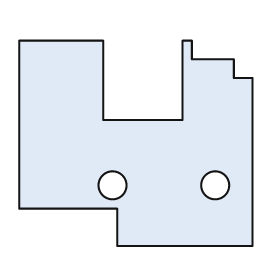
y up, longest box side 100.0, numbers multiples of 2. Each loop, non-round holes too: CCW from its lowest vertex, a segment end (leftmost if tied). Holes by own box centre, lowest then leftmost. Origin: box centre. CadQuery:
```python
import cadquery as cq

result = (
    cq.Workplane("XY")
    .moveTo(-8.0, -44.0)
    .lineTo(50.0, -44.0)
    .lineTo(50.0, 28.0)
    .lineTo(42.0, 28.0)
    .lineTo(42.0, 36.0)
    .lineTo(24.0, 36.0)
    .lineTo(24.0, 44.0)
    .lineTo(20.0, 44.0)
    .lineTo(20.0, 10.0)
    .lineTo(-14.0, 10.0)
    .lineTo(-14.0, 44.0)
    .lineTo(-50.0, 44.0)
    .lineTo(-50.0, -28.0)
    .lineTo(-8.0, -28.0)
    .close()
    .moveTo(-10.0, -18.0)
    .circle(6.0)
    .moveTo(34.0, -18.0)
    .circle(6.0)
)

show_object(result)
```